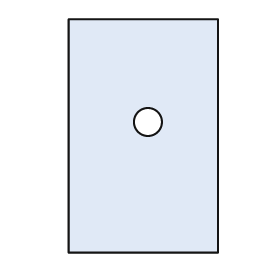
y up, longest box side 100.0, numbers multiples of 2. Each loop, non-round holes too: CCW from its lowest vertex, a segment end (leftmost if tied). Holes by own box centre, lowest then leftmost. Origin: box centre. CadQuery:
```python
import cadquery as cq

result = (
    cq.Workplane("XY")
    .moveTo(-32.0, -50.0)
    .lineTo(32.0, -50.0)
    .lineTo(32.0, 50.0)
    .lineTo(-32.0, 50.0)
    .close()
    .moveTo(2.0, 6.0)
    .circle(6.0)
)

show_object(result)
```